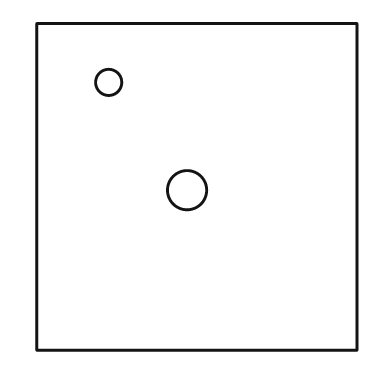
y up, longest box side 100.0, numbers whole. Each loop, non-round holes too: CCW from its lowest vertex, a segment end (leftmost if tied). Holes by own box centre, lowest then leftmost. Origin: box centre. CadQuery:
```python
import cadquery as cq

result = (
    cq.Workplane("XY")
    .moveTo(-49.0, -50.0)
    .lineTo(49.0, -50.0)
    .lineTo(49.0, 50.0)
    .lineTo(-49.0, 50.0)
    .close()
    .moveTo(-3.0, -1.0)
    .circle(6.0)
    .moveTo(-27.0, 32.0)
    .circle(4.0)
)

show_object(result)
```